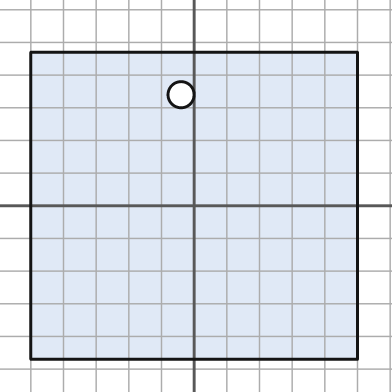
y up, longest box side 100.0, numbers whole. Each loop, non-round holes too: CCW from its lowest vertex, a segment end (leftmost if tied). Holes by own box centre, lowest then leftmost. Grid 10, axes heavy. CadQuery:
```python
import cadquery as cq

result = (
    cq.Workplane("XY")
    .moveTo(-50.0, -47.0)
    .lineTo(50.0, -47.0)
    .lineTo(50.0, 47.0)
    .lineTo(-50.0, 47.0)
    .close()
    .moveTo(-4.0, 34.0)
    .circle(4.0)
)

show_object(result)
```